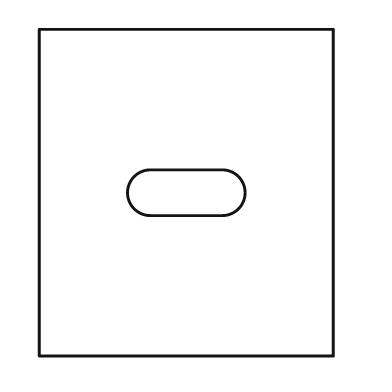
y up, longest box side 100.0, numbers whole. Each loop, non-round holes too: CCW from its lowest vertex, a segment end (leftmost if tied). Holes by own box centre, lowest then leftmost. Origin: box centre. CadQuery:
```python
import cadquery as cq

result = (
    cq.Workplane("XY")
    .moveTo(-45.0, -50.0)
    .lineTo(45.0, -50.0)
    .lineTo(45.0, 50.0)
    .lineTo(-45.0, 50.0)
    .close()
    .moveTo(-11.0, -7.0)
    .lineTo(11.0, -7.0)
    .threePointArc((18.0, 0.0), (11.0, 7.0))
    .lineTo(-11.0, 7.0)
    .threePointArc((-18.0, 0.0), (-11.0, -7.0))
    .close()
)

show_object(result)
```